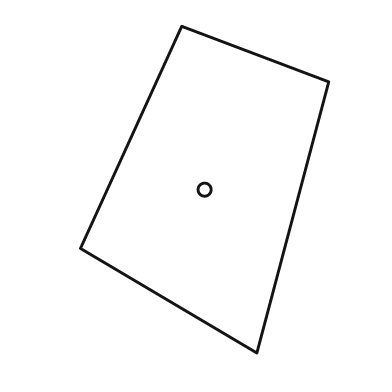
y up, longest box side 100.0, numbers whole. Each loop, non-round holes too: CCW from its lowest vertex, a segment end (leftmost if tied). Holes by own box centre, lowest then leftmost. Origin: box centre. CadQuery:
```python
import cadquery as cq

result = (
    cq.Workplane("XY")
    .moveTo(16.0, -50.0)
    .lineTo(38.0, 33.0)
    .lineTo(-7.0, 50.0)
    .lineTo(-38.0, -18.0)
    .close()
    .moveTo(0.0, 0.0)
    .circle(2.0)
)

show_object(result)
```